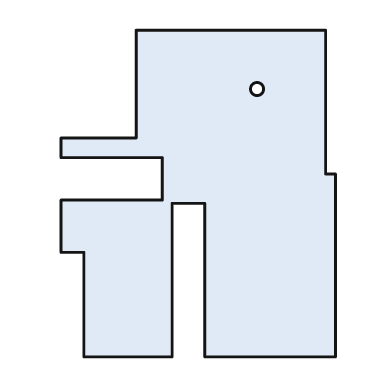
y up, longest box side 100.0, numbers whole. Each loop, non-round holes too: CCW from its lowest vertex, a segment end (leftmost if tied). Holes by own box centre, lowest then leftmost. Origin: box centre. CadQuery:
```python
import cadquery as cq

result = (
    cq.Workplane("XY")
    .moveTo(-35.0, -50.0)
    .lineTo(-8.0, -50.0)
    .lineTo(-8.0, -3.0)
    .lineTo(2.0, -3.0)
    .lineTo(2.0, -50.0)
    .lineTo(42.0, -50.0)
    .lineTo(42.0, 6.0)
    .lineTo(39.0, 6.0)
    .lineTo(39.0, 50.0)
    .lineTo(-19.0, 50.0)
    .lineTo(-19.0, 17.0)
    .lineTo(-42.0, 17.0)
    .lineTo(-42.0, 11.0)
    .lineTo(-11.0, 11.0)
    .lineTo(-11.0, -2.0)
    .lineTo(-42.0, -2.0)
    .lineTo(-42.0, -18.0)
    .lineTo(-35.0, -18.0)
    .close()
    .moveTo(18.0, 32.0)
    .circle(2.0)
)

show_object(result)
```